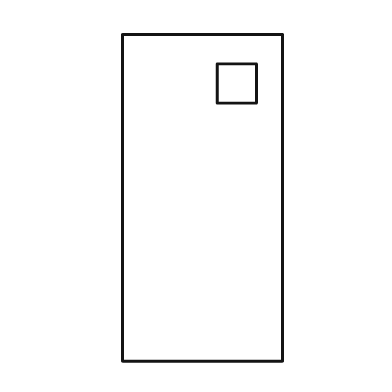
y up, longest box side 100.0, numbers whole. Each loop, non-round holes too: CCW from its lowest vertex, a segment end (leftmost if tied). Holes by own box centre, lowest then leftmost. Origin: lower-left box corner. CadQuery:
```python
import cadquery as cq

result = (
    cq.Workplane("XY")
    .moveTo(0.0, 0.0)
    .lineTo(49.0, 0.0)
    .lineTo(49.0, 100.0)
    .lineTo(0.0, 100.0)
    .close()
    .moveTo(29.0, 79.0)
    .lineTo(41.0, 79.0)
    .lineTo(41.0, 91.0)
    .lineTo(29.0, 91.0)
    .close()
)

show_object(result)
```